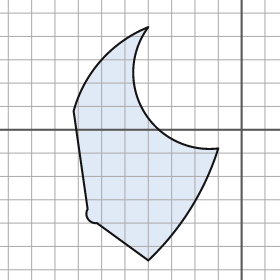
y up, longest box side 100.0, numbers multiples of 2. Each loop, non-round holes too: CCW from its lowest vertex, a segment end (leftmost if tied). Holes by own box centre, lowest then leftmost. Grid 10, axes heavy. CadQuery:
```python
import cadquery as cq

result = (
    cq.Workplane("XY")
    .moveTo(-40.0, -56.0)
    .threePointArc((-22.0, -34.0), (-10.0, -8.0))
    .threePointArc((-42.0, 8.0), (-40.0, 44.0))
    .threePointArc((-60.0, 30.0), (-72.0, 8.0))
    .lineTo(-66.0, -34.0)
    .threePointArc((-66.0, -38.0), (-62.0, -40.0))
    .close()
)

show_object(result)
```